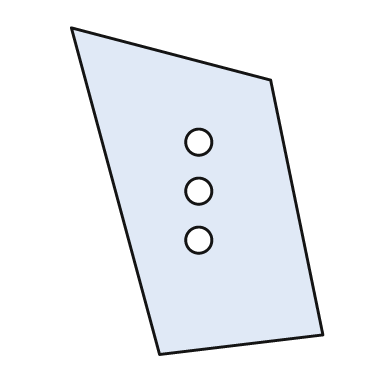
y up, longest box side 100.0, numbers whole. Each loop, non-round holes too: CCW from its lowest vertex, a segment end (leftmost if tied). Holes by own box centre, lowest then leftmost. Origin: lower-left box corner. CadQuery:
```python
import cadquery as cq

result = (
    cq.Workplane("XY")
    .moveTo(27.0, 0.0)
    .lineTo(77.0, 6.0)
    .lineTo(61.0, 84.0)
    .lineTo(0.0, 100.0)
    .close()
    .moveTo(39.0, 35.0)
    .circle(4.0)
    .moveTo(39.0, 50.0)
    .circle(4.0)
    .moveTo(39.0, 65.0)
    .circle(4.0)
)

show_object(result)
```